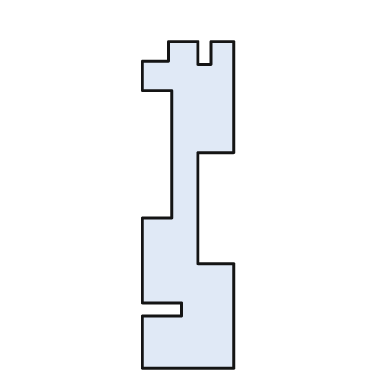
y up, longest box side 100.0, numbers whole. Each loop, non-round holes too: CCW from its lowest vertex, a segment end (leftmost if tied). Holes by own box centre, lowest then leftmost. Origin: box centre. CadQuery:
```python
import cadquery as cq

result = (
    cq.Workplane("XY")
    .moveTo(-14.0, -50.0)
    .lineTo(14.0, -50.0)
    .lineTo(14.0, -18.0)
    .lineTo(3.0, -18.0)
    .lineTo(3.0, 16.0)
    .lineTo(14.0, 16.0)
    .lineTo(14.0, 50.0)
    .lineTo(7.0, 50.0)
    .lineTo(7.0, 43.0)
    .lineTo(3.0, 43.0)
    .lineTo(3.0, 50.0)
    .lineTo(-6.0, 50.0)
    .lineTo(-6.0, 44.0)
    .lineTo(-14.0, 44.0)
    .lineTo(-14.0, 35.0)
    .lineTo(-5.0, 35.0)
    .lineTo(-5.0, -4.0)
    .lineTo(-14.0, -4.0)
    .lineTo(-14.0, -30.0)
    .lineTo(-2.0, -30.0)
    .lineTo(-2.0, -34.0)
    .lineTo(-14.0, -34.0)
    .close()
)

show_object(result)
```